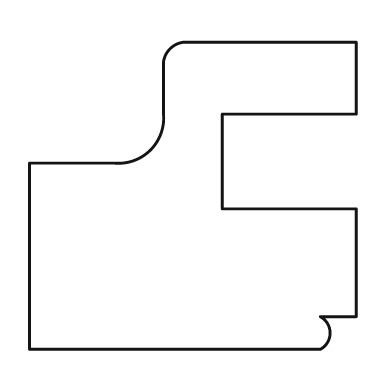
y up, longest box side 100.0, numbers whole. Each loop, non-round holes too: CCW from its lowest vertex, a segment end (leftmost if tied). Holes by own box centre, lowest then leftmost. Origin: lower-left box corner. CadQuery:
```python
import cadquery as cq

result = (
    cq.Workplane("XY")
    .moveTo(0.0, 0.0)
    .lineTo(89.0, 0.0)
    .threePointArc((92.0, 5.0), (89.0, 10.0))
    .lineTo(100.0, 10.0)
    .lineTo(100.0, 43.0)
    .lineTo(59.0, 43.0)
    .lineTo(59.0, 72.0)
    .lineTo(100.0, 72.0)
    .lineTo(100.0, 94.0)
    .lineTo(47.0, 94.0)
    .threePointArc((43.0, 92.0), (41.0, 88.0))
    .lineTo(41.0, 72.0)
    .threePointArc((37.0, 61.0), (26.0, 57.0))
    .lineTo(0.0, 57.0)
    .close()
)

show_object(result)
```